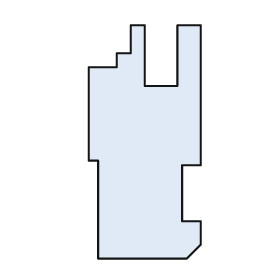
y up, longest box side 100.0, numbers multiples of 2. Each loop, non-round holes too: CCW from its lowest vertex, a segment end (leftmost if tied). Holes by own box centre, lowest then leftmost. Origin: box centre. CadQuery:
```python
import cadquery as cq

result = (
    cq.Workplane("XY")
    .moveTo(-20.0, -50.0)
    .lineTo(18.0, -50.0)
    .lineTo(24.0, -44.0)
    .lineTo(24.0, -34.0)
    .lineTo(16.0, -34.0)
    .lineTo(16.0, -10.0)
    .lineTo(24.0, -10.0)
    .lineTo(24.0, 50.0)
    .lineTo(14.0, 50.0)
    .lineTo(14.0, 24.0)
    .lineTo(0.0, 24.0)
    .lineTo(0.0, 50.0)
    .lineTo(-6.0, 50.0)
    .lineTo(-6.0, 38.0)
    .lineTo(-12.0, 38.0)
    .lineTo(-12.0, 32.0)
    .lineTo(-24.0, 32.0)
    .lineTo(-24.0, -8.0)
    .lineTo(-20.0, -8.0)
    .close()
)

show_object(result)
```